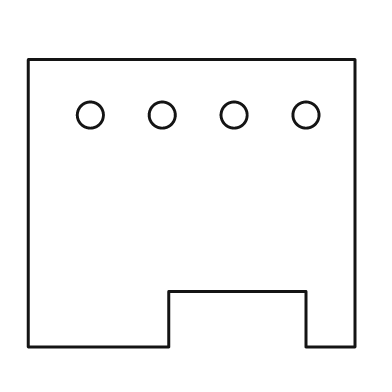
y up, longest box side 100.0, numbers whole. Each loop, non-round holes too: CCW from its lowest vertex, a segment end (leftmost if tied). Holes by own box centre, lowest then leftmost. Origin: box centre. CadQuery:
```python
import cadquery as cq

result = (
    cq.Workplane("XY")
    .moveTo(-50.0, -44.0)
    .lineTo(-7.0, -44.0)
    .lineTo(-7.0, -27.0)
    .lineTo(35.0, -27.0)
    .lineTo(35.0, -44.0)
    .lineTo(50.0, -44.0)
    .lineTo(50.0, 44.0)
    .lineTo(-50.0, 44.0)
    .close()
    .moveTo(-31.0, 27.0)
    .circle(4.0)
    .moveTo(-9.0, 27.0)
    .circle(4.0)
    .moveTo(13.0, 27.0)
    .circle(4.0)
    .moveTo(35.0, 27.0)
    .circle(4.0)
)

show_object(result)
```